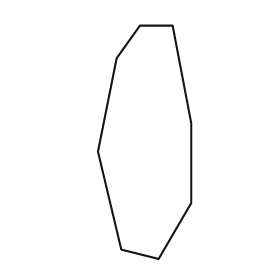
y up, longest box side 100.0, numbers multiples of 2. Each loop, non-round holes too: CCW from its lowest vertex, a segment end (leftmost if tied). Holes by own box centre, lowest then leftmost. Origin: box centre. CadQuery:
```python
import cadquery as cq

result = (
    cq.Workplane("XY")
    .moveTo(6.0, -50.0)
    .lineTo(20.0, -26.0)
    .lineTo(20.0, 8.0)
    .lineTo(12.0, 50.0)
    .lineTo(-2.0, 50.0)
    .lineTo(-12.0, 36.0)
    .lineTo(-20.0, -4.0)
    .lineTo(-10.0, -46.0)
    .close()
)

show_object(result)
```